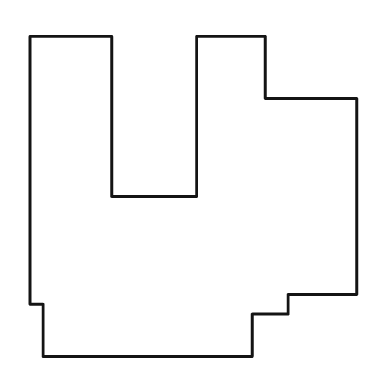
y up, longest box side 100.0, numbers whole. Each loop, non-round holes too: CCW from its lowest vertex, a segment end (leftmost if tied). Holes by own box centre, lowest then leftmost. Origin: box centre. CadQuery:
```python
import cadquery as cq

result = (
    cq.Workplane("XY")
    .moveTo(-46.0, -49.0)
    .lineTo(18.0, -49.0)
    .lineTo(18.0, -36.0)
    .lineTo(29.0, -36.0)
    .lineTo(29.0, -30.0)
    .lineTo(50.0, -30.0)
    .lineTo(50.0, 30.0)
    .lineTo(22.0, 30.0)
    .lineTo(22.0, 49.0)
    .lineTo(1.0, 49.0)
    .lineTo(1.0, 0.0)
    .lineTo(-25.0, 0.0)
    .lineTo(-25.0, 49.0)
    .lineTo(-50.0, 49.0)
    .lineTo(-50.0, -33.0)
    .lineTo(-46.0, -33.0)
    .close()
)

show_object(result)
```